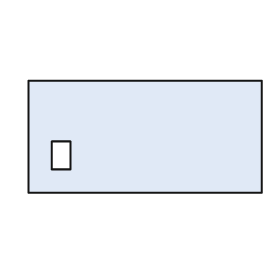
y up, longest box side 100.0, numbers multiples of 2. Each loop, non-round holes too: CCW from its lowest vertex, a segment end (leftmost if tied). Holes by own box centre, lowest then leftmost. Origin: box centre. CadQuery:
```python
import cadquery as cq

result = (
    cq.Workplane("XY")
    .moveTo(-50.0, -24.0)
    .lineTo(50.0, -24.0)
    .lineTo(50.0, 24.0)
    .lineTo(-50.0, 24.0)
    .close()
    .moveTo(-40.0, -14.0)
    .lineTo(-32.0, -14.0)
    .lineTo(-32.0, -2.0)
    .lineTo(-40.0, -2.0)
    .close()
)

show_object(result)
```